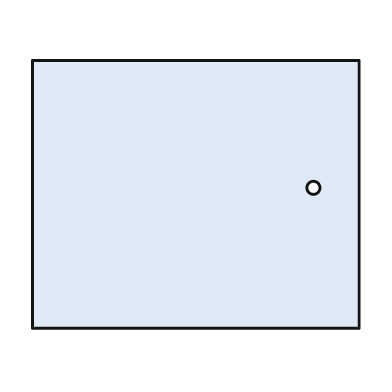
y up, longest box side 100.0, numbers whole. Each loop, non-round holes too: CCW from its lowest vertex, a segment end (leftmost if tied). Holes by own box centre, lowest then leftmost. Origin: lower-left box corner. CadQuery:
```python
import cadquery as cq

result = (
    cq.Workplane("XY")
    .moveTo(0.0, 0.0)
    .lineTo(100.0, 0.0)
    .lineTo(100.0, 82.0)
    .lineTo(0.0, 82.0)
    .close()
    .moveTo(86.0, 43.0)
    .circle(2.0)
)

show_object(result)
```